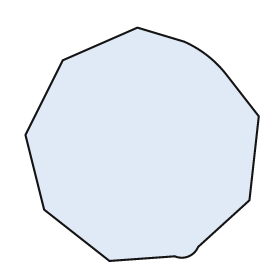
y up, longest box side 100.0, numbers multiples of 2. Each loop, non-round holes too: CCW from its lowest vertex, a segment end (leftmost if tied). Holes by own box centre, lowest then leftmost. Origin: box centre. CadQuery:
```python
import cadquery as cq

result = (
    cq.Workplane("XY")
    .moveTo(-14.0, -50.0)
    .lineTo(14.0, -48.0)
    .threePointArc((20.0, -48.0), (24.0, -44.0))
    .lineTo(46.0, -24.0)
    .lineTo(50.0, 12.0)
    .lineTo(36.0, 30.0)
    .threePointArc((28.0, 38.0), (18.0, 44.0))
    .lineTo(-2.0, 50.0)
    .lineTo(-34.0, 36.0)
    .lineTo(-50.0, 4.0)
    .lineTo(-42.0, -28.0)
    .close()
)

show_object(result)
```